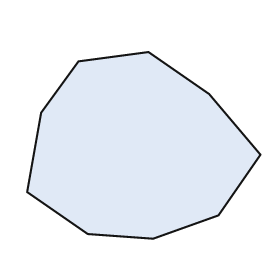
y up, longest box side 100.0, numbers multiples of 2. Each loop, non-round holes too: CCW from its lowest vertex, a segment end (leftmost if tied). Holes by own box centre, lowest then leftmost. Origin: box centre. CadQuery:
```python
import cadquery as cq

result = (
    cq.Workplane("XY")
    .moveTo(4.0, -40.0)
    .lineTo(32.0, -30.0)
    .lineTo(50.0, -4.0)
    .lineTo(28.0, 22.0)
    .lineTo(2.0, 40.0)
    .lineTo(-28.0, 36.0)
    .lineTo(-44.0, 14.0)
    .lineTo(-50.0, -20.0)
    .lineTo(-24.0, -38.0)
    .close()
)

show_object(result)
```